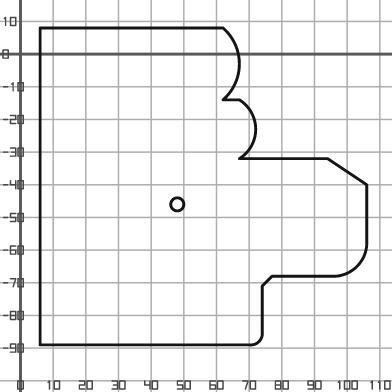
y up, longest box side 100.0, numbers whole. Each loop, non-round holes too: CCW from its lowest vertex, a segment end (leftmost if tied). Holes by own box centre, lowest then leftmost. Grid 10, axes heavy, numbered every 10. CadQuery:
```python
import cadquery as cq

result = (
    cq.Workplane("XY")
    .moveTo(6.0, -89.0)
    .lineTo(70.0, -89.0)
    .threePointArc((73.0, -88.0), (74.0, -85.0))
    .lineTo(74.0, -71.0)
    .lineTo(77.0, -68.0)
    .lineTo(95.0, -68.0)
    .threePointArc((103.0, -65.0), (106.0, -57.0))
    .lineTo(106.0, -40.0)
    .lineTo(94.0, -32.0)
    .lineTo(67.0, -32.0)
    .threePointArc((72.0, -23.0), (67.0, -14.0))
    .lineTo(62.0, -14.0)
    .threePointArc((67.0, -3.0), (62.0, 8.0))
    .lineTo(6.0, 8.0)
    .close()
    .moveTo(48.0, -46.0)
    .circle(2.0)
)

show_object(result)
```